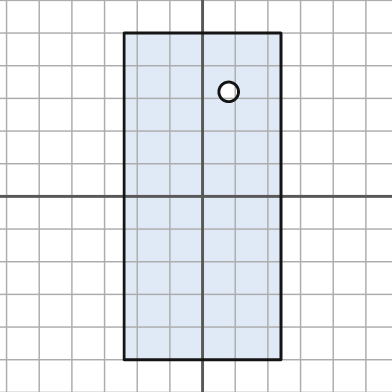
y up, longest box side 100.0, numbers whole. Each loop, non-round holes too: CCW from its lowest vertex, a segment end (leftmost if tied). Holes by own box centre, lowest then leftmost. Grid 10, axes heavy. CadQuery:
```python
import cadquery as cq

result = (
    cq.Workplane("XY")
    .moveTo(-24.0, -50.0)
    .lineTo(24.0, -50.0)
    .lineTo(24.0, 50.0)
    .lineTo(-24.0, 50.0)
    .close()
    .moveTo(8.0, 32.0)
    .circle(3.0)
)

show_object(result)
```